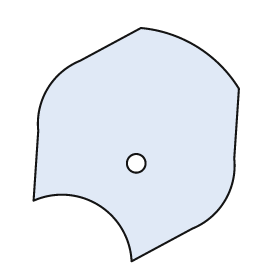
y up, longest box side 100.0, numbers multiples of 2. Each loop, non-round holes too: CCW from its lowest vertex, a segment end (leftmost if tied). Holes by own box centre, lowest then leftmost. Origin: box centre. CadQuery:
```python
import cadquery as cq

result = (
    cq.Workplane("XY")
    .moveTo(-2.0, -50.0)
    .lineTo(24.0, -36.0)
    .threePointArc((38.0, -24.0), (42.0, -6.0))
    .lineTo(44.0, 24.0)
    .threePointArc((26.0, 42.0), (2.0, 50.0))
    .lineTo(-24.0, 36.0)
    .threePointArc((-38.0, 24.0), (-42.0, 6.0))
    .lineTo(-44.0, -24.0)
    .threePointArc((-16.0, -26.0), (-2.0, -50.0))
    .close()
    .moveTo(0.0, -8.0)
    .circle(4.0)
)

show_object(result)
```